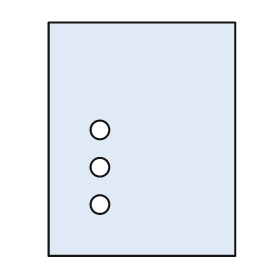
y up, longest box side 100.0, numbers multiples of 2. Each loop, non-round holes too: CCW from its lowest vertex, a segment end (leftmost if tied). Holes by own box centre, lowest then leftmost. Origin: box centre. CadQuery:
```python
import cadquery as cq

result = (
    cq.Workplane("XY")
    .moveTo(-40.0, -50.0)
    .lineTo(40.0, -50.0)
    .lineTo(40.0, 50.0)
    .lineTo(-40.0, 50.0)
    .close()
    .moveTo(-18.0, -28.0)
    .circle(4.0)
    .moveTo(-18.0, -12.0)
    .circle(4.0)
    .moveTo(-18.0, 4.0)
    .circle(4.0)
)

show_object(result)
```